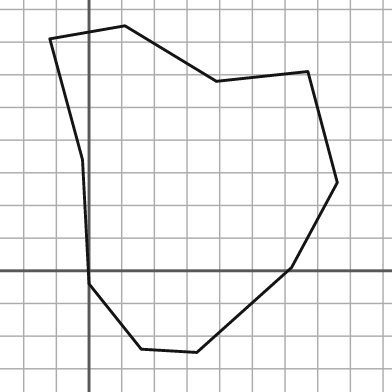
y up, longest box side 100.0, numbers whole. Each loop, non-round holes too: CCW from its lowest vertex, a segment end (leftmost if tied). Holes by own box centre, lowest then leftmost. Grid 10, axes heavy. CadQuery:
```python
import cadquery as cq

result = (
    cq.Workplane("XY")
    .moveTo(33.0, -25.0)
    .lineTo(62.0, 1.0)
    .lineTo(76.0, 27.0)
    .lineTo(67.0, 61.0)
    .lineTo(39.0, 58.0)
    .lineTo(11.0, 75.0)
    .lineTo(-12.0, 71.0)
    .lineTo(-2.0, 34.0)
    .lineTo(0.0, -4.0)
    .lineTo(16.0, -24.0)
    .close()
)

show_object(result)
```